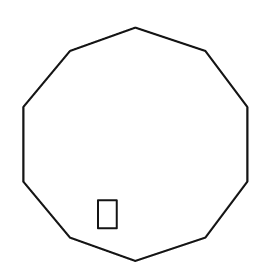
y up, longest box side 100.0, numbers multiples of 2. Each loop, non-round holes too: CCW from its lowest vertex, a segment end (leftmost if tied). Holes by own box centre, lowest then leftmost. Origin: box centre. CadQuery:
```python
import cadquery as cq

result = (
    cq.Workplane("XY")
    .moveTo(0.0, -50.0)
    .lineTo(30.0, -40.0)
    .lineTo(48.0, -16.0)
    .lineTo(48.0, 16.0)
    .lineTo(30.0, 40.0)
    .lineTo(0.0, 50.0)
    .lineTo(-28.0, 40.0)
    .lineTo(-48.0, 16.0)
    .lineTo(-48.0, -16.0)
    .lineTo(-28.0, -40.0)
    .close()
    .moveTo(-16.0, -36.0)
    .lineTo(-8.0, -36.0)
    .lineTo(-8.0, -24.0)
    .lineTo(-16.0, -24.0)
    .close()
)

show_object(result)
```